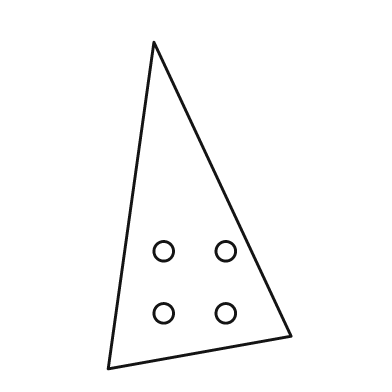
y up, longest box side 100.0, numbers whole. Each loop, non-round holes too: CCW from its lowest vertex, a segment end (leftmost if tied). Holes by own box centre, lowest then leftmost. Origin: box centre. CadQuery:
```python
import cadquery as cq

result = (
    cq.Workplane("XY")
    .moveTo(-28.0, -50.0)
    .lineTo(28.0, -40.0)
    .lineTo(-14.0, 50.0)
    .close()
    .moveTo(-11.0, -33.0)
    .circle(3.0)
    .moveTo(8.0, -33.0)
    .circle(3.0)
    .moveTo(-11.0, -14.0)
    .circle(3.0)
    .moveTo(8.0, -14.0)
    .circle(3.0)
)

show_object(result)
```